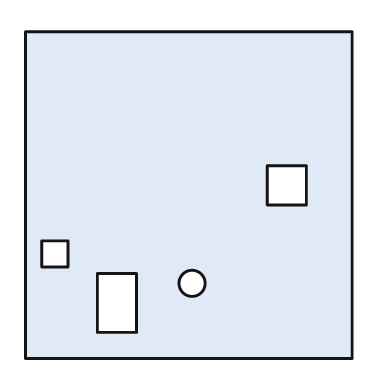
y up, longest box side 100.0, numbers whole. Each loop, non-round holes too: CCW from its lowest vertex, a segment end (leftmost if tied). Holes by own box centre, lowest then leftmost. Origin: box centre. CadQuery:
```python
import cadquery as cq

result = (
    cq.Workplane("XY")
    .moveTo(-50.0, -50.0)
    .lineTo(50.0, -50.0)
    .lineTo(50.0, 50.0)
    .lineTo(-50.0, 50.0)
    .close()
    .moveTo(-28.0, -42.0)
    .lineTo(-16.0, -42.0)
    .lineTo(-16.0, -24.0)
    .lineTo(-28.0, -24.0)
    .close()
    .moveTo(1.0, -27.0)
    .circle(4.0)
    .moveTo(-45.0, -22.0)
    .lineTo(-37.0, -22.0)
    .lineTo(-37.0, -14.0)
    .lineTo(-45.0, -14.0)
    .close()
    .moveTo(24.0, -3.0)
    .lineTo(36.0, -3.0)
    .lineTo(36.0, 9.0)
    .lineTo(24.0, 9.0)
    .close()
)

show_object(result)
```